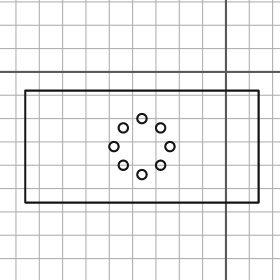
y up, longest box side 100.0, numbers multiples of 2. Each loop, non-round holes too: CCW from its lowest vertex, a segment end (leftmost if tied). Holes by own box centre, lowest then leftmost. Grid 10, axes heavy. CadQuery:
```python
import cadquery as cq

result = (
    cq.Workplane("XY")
    .moveTo(-86.0, -56.0)
    .lineTo(14.0, -56.0)
    .lineTo(14.0, -8.0)
    .lineTo(-86.0, -8.0)
    .close()
    .moveTo(-36.0, -44.0)
    .circle(2.0)
    .moveTo(-44.0, -40.0)
    .circle(2.0)
    .moveTo(-28.0, -40.0)
    .circle(2.0)
    .moveTo(-48.0, -32.0)
    .circle(2.0)
    .moveTo(-24.0, -32.0)
    .circle(2.0)
    .moveTo(-44.0, -24.0)
    .circle(2.0)
    .moveTo(-28.0, -24.0)
    .circle(2.0)
    .moveTo(-36.0, -20.0)
    .circle(2.0)
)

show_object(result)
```